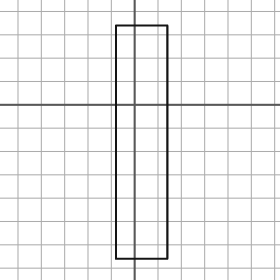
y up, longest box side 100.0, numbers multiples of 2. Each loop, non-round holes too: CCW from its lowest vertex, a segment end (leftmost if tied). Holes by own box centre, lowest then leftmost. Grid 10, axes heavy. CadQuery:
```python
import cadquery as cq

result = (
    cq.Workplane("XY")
    .moveTo(-8.0, -66.0)
    .lineTo(14.0, -66.0)
    .lineTo(14.0, 34.0)
    .lineTo(-8.0, 34.0)
    .close()
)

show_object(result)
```